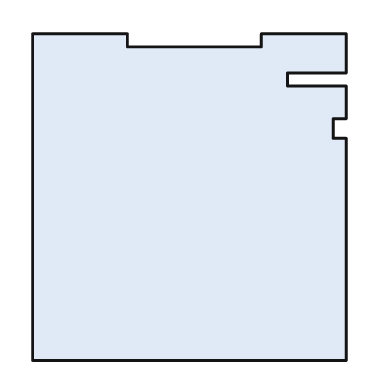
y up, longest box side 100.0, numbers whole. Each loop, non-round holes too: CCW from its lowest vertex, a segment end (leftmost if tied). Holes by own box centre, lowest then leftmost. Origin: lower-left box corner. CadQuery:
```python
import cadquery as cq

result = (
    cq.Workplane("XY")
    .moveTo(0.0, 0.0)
    .lineTo(96.0, 0.0)
    .lineTo(96.0, 68.0)
    .lineTo(92.0, 68.0)
    .lineTo(92.0, 74.0)
    .lineTo(96.0, 74.0)
    .lineTo(96.0, 84.0)
    .lineTo(78.0, 84.0)
    .lineTo(78.0, 88.0)
    .lineTo(96.0, 88.0)
    .lineTo(96.0, 100.0)
    .lineTo(70.0, 100.0)
    .lineTo(70.0, 96.0)
    .lineTo(29.0, 96.0)
    .lineTo(29.0, 100.0)
    .lineTo(0.0, 100.0)
    .close()
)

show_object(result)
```